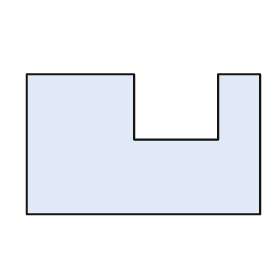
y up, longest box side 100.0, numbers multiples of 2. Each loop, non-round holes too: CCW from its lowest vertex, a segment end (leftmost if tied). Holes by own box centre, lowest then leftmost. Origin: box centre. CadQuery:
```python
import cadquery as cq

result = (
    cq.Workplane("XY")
    .moveTo(-50.0, -30.0)
    .lineTo(50.0, -30.0)
    .lineTo(50.0, 30.0)
    .lineTo(32.0, 30.0)
    .lineTo(32.0, 2.0)
    .lineTo(-4.0, 2.0)
    .lineTo(-4.0, 30.0)
    .lineTo(-50.0, 30.0)
    .close()
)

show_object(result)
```